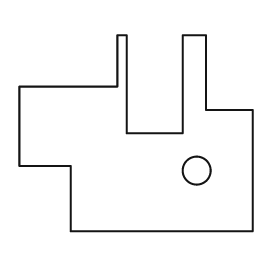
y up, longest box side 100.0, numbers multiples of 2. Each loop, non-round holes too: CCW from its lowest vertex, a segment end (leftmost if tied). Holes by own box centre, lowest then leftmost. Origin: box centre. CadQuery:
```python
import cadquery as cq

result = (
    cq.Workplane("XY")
    .moveTo(-28.0, -42.0)
    .lineTo(50.0, -42.0)
    .lineTo(50.0, 10.0)
    .lineTo(30.0, 10.0)
    .lineTo(30.0, 42.0)
    .lineTo(20.0, 42.0)
    .lineTo(20.0, 0.0)
    .lineTo(-4.0, 0.0)
    .lineTo(-4.0, 42.0)
    .lineTo(-8.0, 42.0)
    .lineTo(-8.0, 20.0)
    .lineTo(-50.0, 20.0)
    .lineTo(-50.0, -14.0)
    .lineTo(-28.0, -14.0)
    .close()
    .moveTo(26.0, -16.0)
    .circle(6.0)
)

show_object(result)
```